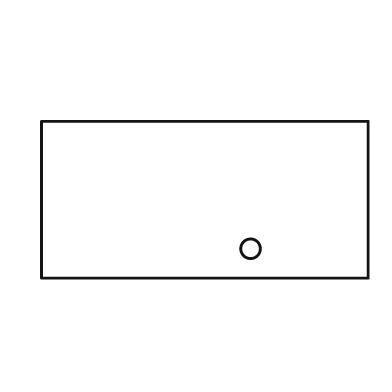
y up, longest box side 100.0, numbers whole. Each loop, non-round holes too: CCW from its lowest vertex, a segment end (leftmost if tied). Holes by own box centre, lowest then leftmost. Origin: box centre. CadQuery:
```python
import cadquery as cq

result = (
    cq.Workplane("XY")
    .moveTo(-50.0, -24.0)
    .lineTo(50.0, -24.0)
    .lineTo(50.0, 24.0)
    .lineTo(-50.0, 24.0)
    .close()
    .moveTo(14.0, -15.0)
    .circle(3.0)
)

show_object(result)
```